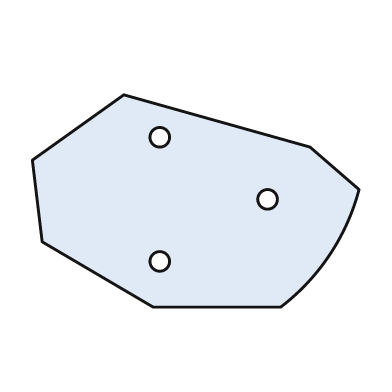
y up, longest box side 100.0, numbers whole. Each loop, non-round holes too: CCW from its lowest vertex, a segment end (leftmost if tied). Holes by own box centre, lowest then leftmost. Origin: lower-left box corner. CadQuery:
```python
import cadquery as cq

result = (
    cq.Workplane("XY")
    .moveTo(37.0, 0.0)
    .lineTo(76.0, 0.0)
    .threePointArc((91.0, 16.0), (100.0, 36.0))
    .lineTo(85.0, 49.0)
    .lineTo(28.0, 65.0)
    .lineTo(0.0, 45.0)
    .lineTo(3.0, 20.0)
    .close()
    .moveTo(39.0, 14.0)
    .circle(3.0)
    .moveTo(72.0, 33.0)
    .circle(3.0)
    .moveTo(39.0, 52.0)
    .circle(3.0)
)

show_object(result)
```